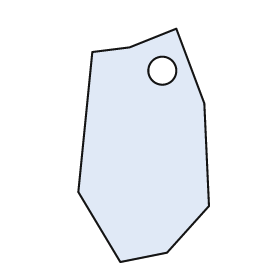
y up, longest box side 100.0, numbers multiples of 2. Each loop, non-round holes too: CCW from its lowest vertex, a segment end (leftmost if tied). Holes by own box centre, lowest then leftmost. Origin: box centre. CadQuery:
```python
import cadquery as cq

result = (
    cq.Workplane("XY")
    .moveTo(-10.0, -50.0)
    .lineTo(10.0, -46.0)
    .lineTo(28.0, -26.0)
    .lineTo(26.0, 18.0)
    .lineTo(14.0, 50.0)
    .lineTo(-6.0, 42.0)
    .lineTo(-22.0, 40.0)
    .lineTo(-28.0, -20.0)
    .close()
    .moveTo(8.0, 32.0)
    .circle(6.0)
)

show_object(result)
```